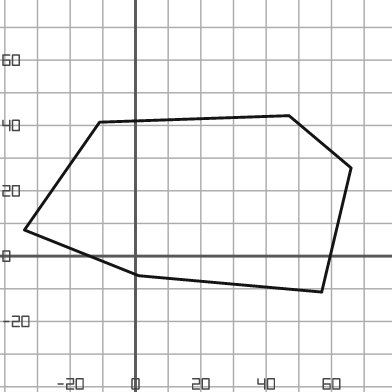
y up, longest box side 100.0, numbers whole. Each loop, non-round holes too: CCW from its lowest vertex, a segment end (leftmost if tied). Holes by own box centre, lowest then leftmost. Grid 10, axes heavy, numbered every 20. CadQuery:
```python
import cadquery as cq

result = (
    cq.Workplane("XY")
    .moveTo(57.0, -11.0)
    .lineTo(66.0, 27.0)
    .lineTo(47.0, 43.0)
    .lineTo(-11.0, 41.0)
    .lineTo(-34.0, 8.0)
    .lineTo(1.0, -6.0)
    .close()
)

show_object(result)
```